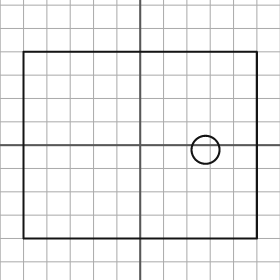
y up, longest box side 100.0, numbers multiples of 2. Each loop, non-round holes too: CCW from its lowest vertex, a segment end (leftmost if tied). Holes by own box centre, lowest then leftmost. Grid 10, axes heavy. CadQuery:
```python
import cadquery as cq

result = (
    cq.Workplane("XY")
    .moveTo(-50.0, -40.0)
    .lineTo(50.0, -40.0)
    .lineTo(50.0, 40.0)
    .lineTo(-50.0, 40.0)
    .close()
    .moveTo(28.0, -2.0)
    .circle(6.0)
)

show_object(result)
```